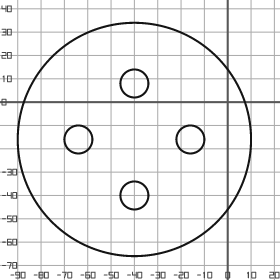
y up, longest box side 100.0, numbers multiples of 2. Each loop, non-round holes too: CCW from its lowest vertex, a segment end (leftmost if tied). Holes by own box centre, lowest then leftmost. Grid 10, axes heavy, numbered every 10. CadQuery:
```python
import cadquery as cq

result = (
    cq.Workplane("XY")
    .moveTo(-40.0, -16.0)
    .circle(50.0)
    .moveTo(-40.0, -40.0)
    .circle(6.0)
    .moveTo(-64.0, -16.0)
    .circle(6.0)
    .moveTo(-16.0, -16.0)
    .circle(6.0)
    .moveTo(-40.0, 8.0)
    .circle(6.0)
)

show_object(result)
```